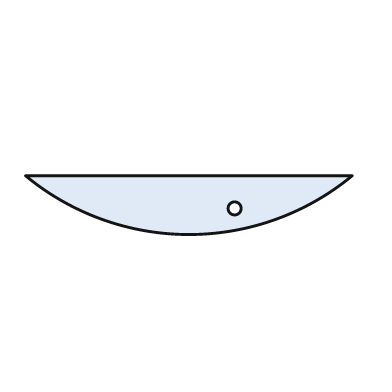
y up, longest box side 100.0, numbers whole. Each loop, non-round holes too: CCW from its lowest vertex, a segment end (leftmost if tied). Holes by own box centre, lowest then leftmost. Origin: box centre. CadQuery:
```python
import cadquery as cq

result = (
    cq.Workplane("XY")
    .moveTo(-50.0, 9.0)
    .threePointArc((0.0, -9.0), (50.0, 9.0))
    .close()
    .moveTo(14.0, -1.0)
    .circle(2.0)
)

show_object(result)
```